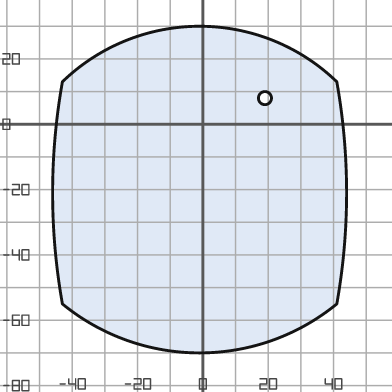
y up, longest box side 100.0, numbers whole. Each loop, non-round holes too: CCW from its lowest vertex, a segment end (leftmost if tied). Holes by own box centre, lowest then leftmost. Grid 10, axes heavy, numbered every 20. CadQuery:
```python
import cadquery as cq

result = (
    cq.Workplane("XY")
    .moveTo(-43.0, -55.0)
    .threePointArc((-1.0, -70.0), (41.0, -55.0))
    .threePointArc((44.0, -21.0), (41.0, 13.0))
    .threePointArc((-1.0, 30.0), (-43.0, 13.0))
    .threePointArc((-46.0, -21.0), (-43.0, -55.0))
    .close()
    .moveTo(19.0, 8.0)
    .circle(2.0)
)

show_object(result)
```